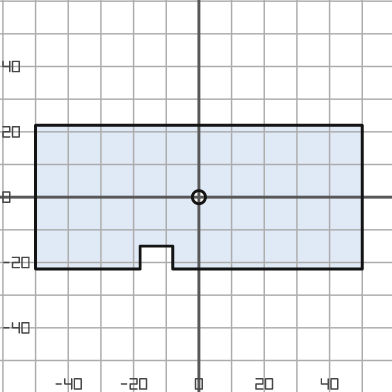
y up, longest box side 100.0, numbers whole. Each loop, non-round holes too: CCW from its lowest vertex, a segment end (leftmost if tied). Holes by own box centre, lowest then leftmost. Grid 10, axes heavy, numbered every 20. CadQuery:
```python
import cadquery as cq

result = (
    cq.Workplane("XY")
    .moveTo(-50.0, -22.0)
    .lineTo(-18.0, -22.0)
    .lineTo(-18.0, -15.0)
    .lineTo(-8.0, -15.0)
    .lineTo(-8.0, -22.0)
    .lineTo(50.0, -22.0)
    .lineTo(50.0, 22.0)
    .lineTo(-50.0, 22.0)
    .close()
    .moveTo(0.0, 0.0)
    .circle(2.0)
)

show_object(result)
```